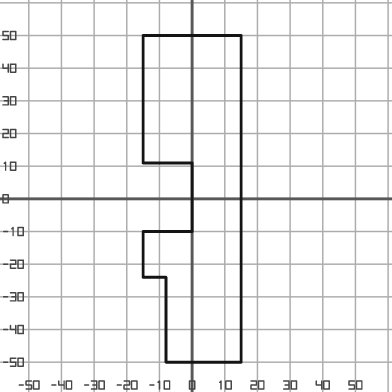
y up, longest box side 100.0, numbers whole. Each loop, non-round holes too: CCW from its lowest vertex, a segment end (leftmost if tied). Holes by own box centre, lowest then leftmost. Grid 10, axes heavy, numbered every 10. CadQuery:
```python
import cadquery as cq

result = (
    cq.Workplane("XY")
    .moveTo(-8.0, -50.0)
    .lineTo(15.0, -50.0)
    .lineTo(15.0, 50.0)
    .lineTo(-15.0, 50.0)
    .lineTo(-15.0, 11.0)
    .lineTo(0.0, 11.0)
    .lineTo(0.0, -10.0)
    .lineTo(-15.0, -10.0)
    .lineTo(-15.0, -24.0)
    .lineTo(-8.0, -24.0)
    .close()
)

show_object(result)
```